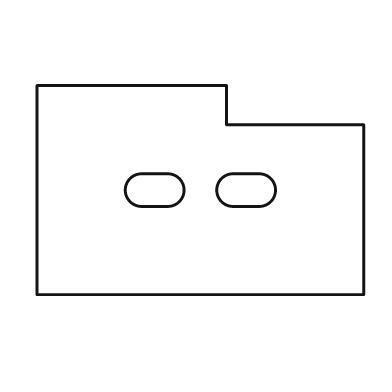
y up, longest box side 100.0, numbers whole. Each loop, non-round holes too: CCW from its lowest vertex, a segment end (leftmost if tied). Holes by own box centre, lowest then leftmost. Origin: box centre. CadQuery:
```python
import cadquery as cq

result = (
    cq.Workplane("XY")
    .moveTo(-50.0, -32.0)
    .lineTo(50.0, -32.0)
    .lineTo(50.0, 20.0)
    .lineTo(8.0, 20.0)
    .lineTo(8.0, 32.0)
    .lineTo(-50.0, 32.0)
    .close()
    .moveTo(-18.0, -5.0)
    .lineTo(-10.0, -5.0)
    .threePointArc((-5.0, 0.0), (-10.0, 5.0))
    .lineTo(-18.0, 5.0)
    .threePointArc((-23.0, 0.0), (-18.0, -5.0))
    .close()
    .moveTo(10.0, -5.0)
    .lineTo(18.0, -5.0)
    .threePointArc((23.0, 0.0), (18.0, 5.0))
    .lineTo(10.0, 5.0)
    .threePointArc((5.0, 0.0), (10.0, -5.0))
    .close()
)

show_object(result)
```